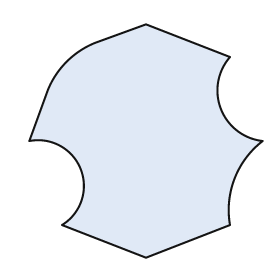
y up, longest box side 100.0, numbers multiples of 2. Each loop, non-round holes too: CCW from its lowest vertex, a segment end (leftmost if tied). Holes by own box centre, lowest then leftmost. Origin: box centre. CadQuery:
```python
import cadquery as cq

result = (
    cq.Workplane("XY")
    .moveTo(0.0, -50.0)
    .lineTo(36.0, -36.0)
    .threePointArc((38.0, -16.0), (50.0, 0.0))
    .threePointArc((32.0, 14.0), (36.0, 36.0))
    .lineTo(0.0, 50.0)
    .lineTo(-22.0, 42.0)
    .threePointArc((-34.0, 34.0), (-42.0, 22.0))
    .lineTo(-50.0, 0.0)
    .threePointArc((-28.0, -12.0), (-36.0, -36.0))
    .close()
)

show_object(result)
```